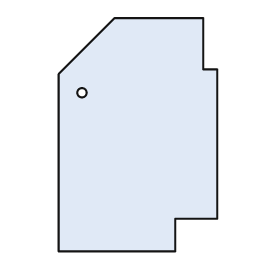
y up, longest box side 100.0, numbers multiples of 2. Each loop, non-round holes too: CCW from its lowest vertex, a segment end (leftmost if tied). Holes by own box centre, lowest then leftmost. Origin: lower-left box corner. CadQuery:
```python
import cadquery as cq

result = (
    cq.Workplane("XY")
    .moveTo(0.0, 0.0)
    .lineTo(50.0, 0.0)
    .lineTo(50.0, 14.0)
    .lineTo(68.0, 14.0)
    .lineTo(68.0, 78.0)
    .lineTo(62.0, 78.0)
    .lineTo(62.0, 100.0)
    .lineTo(24.0, 100.0)
    .lineTo(0.0, 76.0)
    .close()
    .moveTo(10.0, 68.0)
    .circle(2.0)
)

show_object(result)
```